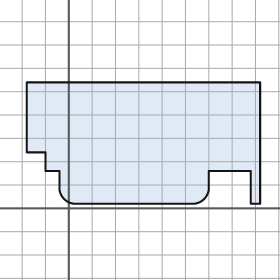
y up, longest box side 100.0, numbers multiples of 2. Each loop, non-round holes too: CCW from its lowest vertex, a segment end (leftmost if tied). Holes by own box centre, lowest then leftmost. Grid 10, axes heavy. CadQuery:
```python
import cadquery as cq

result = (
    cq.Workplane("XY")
    .moveTo(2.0, 2.0)
    .lineTo(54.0, 2.0)
    .threePointArc((58.0, 4.0), (60.0, 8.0))
    .lineTo(60.0, 16.0)
    .lineTo(78.0, 16.0)
    .lineTo(78.0, 2.0)
    .lineTo(82.0, 2.0)
    .lineTo(82.0, 54.0)
    .lineTo(-18.0, 54.0)
    .lineTo(-18.0, 24.0)
    .lineTo(-10.0, 24.0)
    .lineTo(-10.0, 16.0)
    .lineTo(-4.0, 16.0)
    .lineTo(-4.0, 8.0)
    .threePointArc((-2.0, 4.0), (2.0, 2.0))
    .close()
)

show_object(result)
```